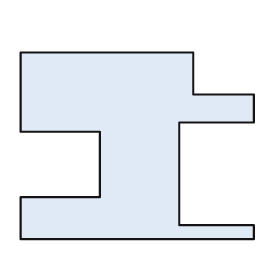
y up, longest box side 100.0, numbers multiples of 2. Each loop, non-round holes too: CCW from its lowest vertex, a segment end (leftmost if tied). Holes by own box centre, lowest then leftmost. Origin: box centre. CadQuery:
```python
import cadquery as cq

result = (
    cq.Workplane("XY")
    .moveTo(-50.0, -40.0)
    .lineTo(50.0, -40.0)
    .lineTo(50.0, -34.0)
    .lineTo(18.0, -34.0)
    .lineTo(18.0, 10.0)
    .lineTo(50.0, 10.0)
    .lineTo(50.0, 22.0)
    .lineTo(24.0, 22.0)
    .lineTo(24.0, 40.0)
    .lineTo(-50.0, 40.0)
    .lineTo(-50.0, 6.0)
    .lineTo(-16.0, 6.0)
    .lineTo(-16.0, -22.0)
    .lineTo(-50.0, -22.0)
    .close()
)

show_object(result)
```